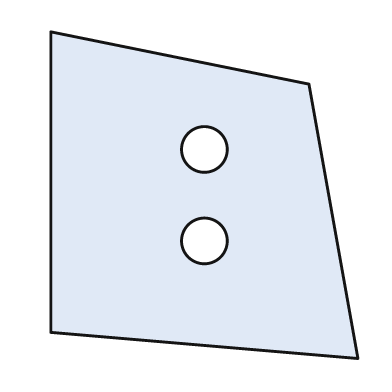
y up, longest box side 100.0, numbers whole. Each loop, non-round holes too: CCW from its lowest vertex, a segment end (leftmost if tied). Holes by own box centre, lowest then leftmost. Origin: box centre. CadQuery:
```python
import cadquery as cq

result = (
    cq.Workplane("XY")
    .moveTo(47.0, -50.0)
    .lineTo(32.0, 34.0)
    .lineTo(-47.0, 50.0)
    .lineTo(-47.0, -42.0)
    .close()
    .moveTo(0.0, -14.0)
    .circle(7.0)
    .moveTo(0.0, 14.0)
    .circle(7.0)
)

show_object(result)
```